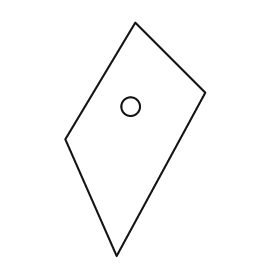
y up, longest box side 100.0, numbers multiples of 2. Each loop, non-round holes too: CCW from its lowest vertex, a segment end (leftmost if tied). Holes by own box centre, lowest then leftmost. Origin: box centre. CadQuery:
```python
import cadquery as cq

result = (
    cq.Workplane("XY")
    .moveTo(-8.0, -50.0)
    .lineTo(30.0, 20.0)
    .lineTo(0.0, 50.0)
    .lineTo(-30.0, 0.0)
    .close()
    .moveTo(-2.0, 14.0)
    .circle(4.0)
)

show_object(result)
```